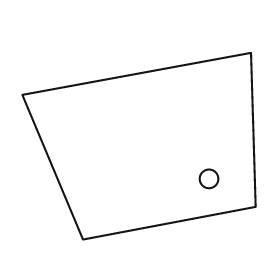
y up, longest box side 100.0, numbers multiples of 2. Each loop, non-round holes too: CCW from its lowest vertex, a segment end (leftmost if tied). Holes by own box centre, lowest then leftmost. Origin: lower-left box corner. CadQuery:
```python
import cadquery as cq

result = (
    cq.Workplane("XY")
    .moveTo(26.0, 0.0)
    .lineTo(100.0, 14.0)
    .lineTo(98.0, 80.0)
    .lineTo(0.0, 62.0)
    .close()
    .moveTo(80.0, 26.0)
    .circle(4.0)
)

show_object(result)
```